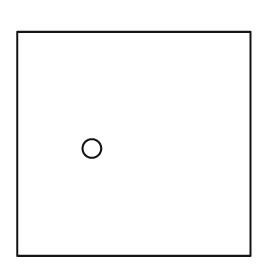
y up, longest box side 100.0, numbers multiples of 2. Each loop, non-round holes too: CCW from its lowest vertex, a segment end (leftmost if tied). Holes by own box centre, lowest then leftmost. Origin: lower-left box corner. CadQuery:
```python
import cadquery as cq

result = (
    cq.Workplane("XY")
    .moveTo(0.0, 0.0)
    .lineTo(100.0, 0.0)
    .lineTo(100.0, 96.0)
    .lineTo(0.0, 96.0)
    .close()
    .moveTo(32.0, 46.0)
    .circle(4.0)
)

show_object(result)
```